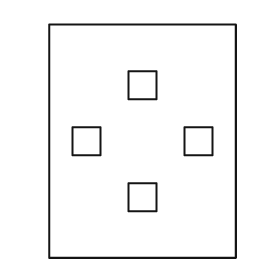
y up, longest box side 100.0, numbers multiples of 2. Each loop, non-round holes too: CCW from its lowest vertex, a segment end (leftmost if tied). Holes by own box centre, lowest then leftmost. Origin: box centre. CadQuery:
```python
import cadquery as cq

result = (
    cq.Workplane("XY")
    .moveTo(-40.0, -50.0)
    .lineTo(40.0, -50.0)
    .lineTo(40.0, 50.0)
    .lineTo(-40.0, 50.0)
    .close()
    .moveTo(-6.0, -30.0)
    .lineTo(6.0, -30.0)
    .lineTo(6.0, -18.0)
    .lineTo(-6.0, -18.0)
    .close()
    .moveTo(-30.0, -6.0)
    .lineTo(-18.0, -6.0)
    .lineTo(-18.0, 6.0)
    .lineTo(-30.0, 6.0)
    .close()
    .moveTo(18.0, -6.0)
    .lineTo(30.0, -6.0)
    .lineTo(30.0, 6.0)
    .lineTo(18.0, 6.0)
    .close()
    .moveTo(-6.0, 18.0)
    .lineTo(6.0, 18.0)
    .lineTo(6.0, 30.0)
    .lineTo(-6.0, 30.0)
    .close()
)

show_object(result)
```